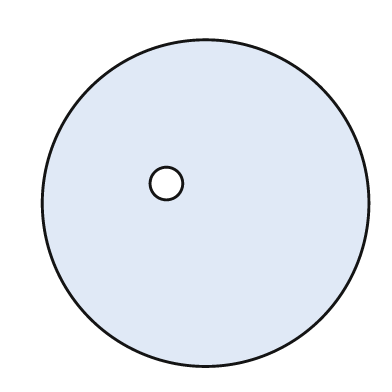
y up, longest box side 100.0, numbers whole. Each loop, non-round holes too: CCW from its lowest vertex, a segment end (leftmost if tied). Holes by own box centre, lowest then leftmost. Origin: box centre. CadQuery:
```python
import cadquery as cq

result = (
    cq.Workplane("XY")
    .moveTo(0.0, 0.0)
    .circle(50.0)
    .moveTo(-12.0, 6.0)
    .circle(5.0)
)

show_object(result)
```